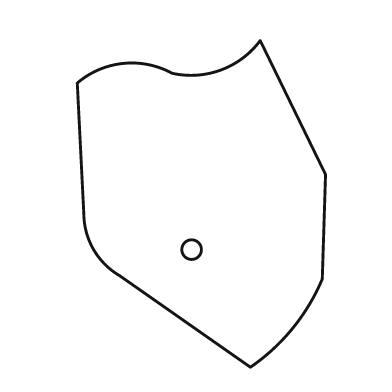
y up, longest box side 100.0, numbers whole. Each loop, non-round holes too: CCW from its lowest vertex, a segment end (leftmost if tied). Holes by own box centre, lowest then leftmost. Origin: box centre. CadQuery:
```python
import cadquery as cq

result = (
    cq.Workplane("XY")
    .moveTo(15.0, -50.0)
    .threePointArc((28.0, -38.0), (37.0, -23.0))
    .lineTo(38.0, 9.0)
    .lineTo(18.0, 50.0)
    .threePointArc((6.0, 41.0), (-9.0, 40.0))
    .threePointArc((-24.0, 43.0), (-38.0, 37.0))
    .lineTo(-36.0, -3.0)
    .threePointArc((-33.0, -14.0), (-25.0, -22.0))
    .close()
    .moveTo(-3.0, -14.0)
    .circle(3.0)
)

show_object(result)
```